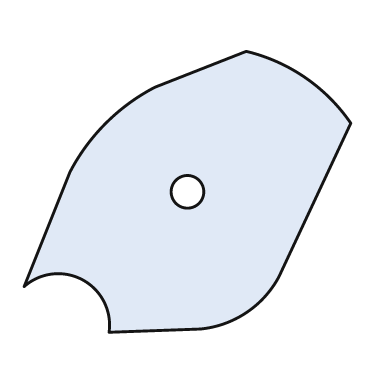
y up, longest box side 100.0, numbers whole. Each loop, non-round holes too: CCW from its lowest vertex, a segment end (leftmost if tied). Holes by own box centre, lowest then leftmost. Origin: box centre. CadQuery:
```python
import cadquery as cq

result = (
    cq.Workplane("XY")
    .moveTo(-24.0, -43.0)
    .lineTo(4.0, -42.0)
    .threePointArc((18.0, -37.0), (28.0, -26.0))
    .lineTo(50.0, 21.0)
    .threePointArc((36.0, 35.0), (18.0, 43.0))
    .lineTo(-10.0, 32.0)
    .threePointArc((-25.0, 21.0), (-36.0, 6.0))
    .lineTo(-50.0, -29.0)
    .threePointArc((-32.0, -27.0), (-24.0, -43.0))
    .close()
    .moveTo(0.0, 0.0)
    .circle(5.0)
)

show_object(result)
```